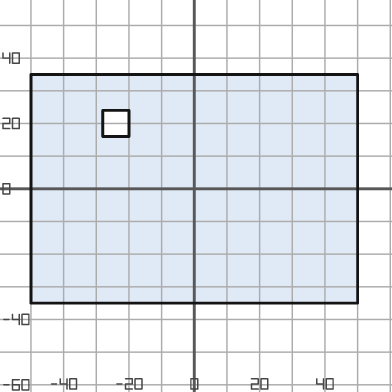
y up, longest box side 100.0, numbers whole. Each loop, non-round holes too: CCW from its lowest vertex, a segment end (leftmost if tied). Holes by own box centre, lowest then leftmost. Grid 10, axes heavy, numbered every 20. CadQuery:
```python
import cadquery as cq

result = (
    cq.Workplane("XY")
    .moveTo(-50.0, -35.0)
    .lineTo(50.0, -35.0)
    .lineTo(50.0, 35.0)
    .lineTo(-50.0, 35.0)
    .close()
    .moveTo(-28.0, 16.0)
    .lineTo(-20.0, 16.0)
    .lineTo(-20.0, 24.0)
    .lineTo(-28.0, 24.0)
    .close()
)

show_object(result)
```